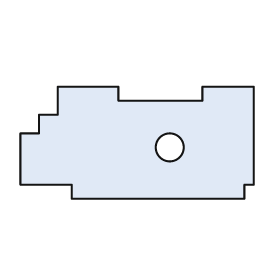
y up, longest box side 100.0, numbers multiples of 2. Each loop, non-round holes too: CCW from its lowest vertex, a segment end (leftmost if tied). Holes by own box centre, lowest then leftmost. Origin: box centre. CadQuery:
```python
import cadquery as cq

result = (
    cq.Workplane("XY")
    .moveTo(-28.0, -24.0)
    .lineTo(46.0, -24.0)
    .lineTo(46.0, -18.0)
    .lineTo(50.0, -18.0)
    .lineTo(50.0, 24.0)
    .lineTo(28.0, 24.0)
    .lineTo(28.0, 18.0)
    .lineTo(-8.0, 18.0)
    .lineTo(-8.0, 24.0)
    .lineTo(-34.0, 24.0)
    .lineTo(-34.0, 12.0)
    .lineTo(-42.0, 12.0)
    .lineTo(-42.0, 4.0)
    .lineTo(-50.0, 4.0)
    .lineTo(-50.0, -18.0)
    .lineTo(-28.0, -18.0)
    .close()
    .moveTo(14.0, -2.0)
    .circle(6.0)
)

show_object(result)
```